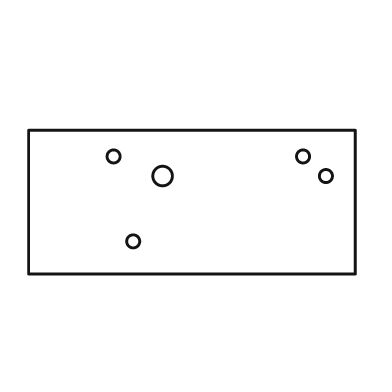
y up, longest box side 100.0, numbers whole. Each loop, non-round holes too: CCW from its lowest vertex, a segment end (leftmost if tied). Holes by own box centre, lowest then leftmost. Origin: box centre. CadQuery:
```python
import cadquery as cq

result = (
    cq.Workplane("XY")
    .moveTo(-50.0, -22.0)
    .lineTo(50.0, -22.0)
    .lineTo(50.0, 22.0)
    .lineTo(-50.0, 22.0)
    .close()
    .moveTo(-18.0, -12.0)
    .circle(2.0)
    .moveTo(-9.0, 8.0)
    .circle(3.0)
    .moveTo(41.0, 8.0)
    .circle(2.0)
    .moveTo(-24.0, 14.0)
    .circle(2.0)
    .moveTo(34.0, 14.0)
    .circle(2.0)
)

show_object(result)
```